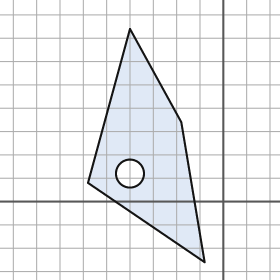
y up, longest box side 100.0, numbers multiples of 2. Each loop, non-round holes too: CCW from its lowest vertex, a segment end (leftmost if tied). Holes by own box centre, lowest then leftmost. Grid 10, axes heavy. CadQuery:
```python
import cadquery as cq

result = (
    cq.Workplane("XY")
    .moveTo(-8.0, -26.0)
    .lineTo(-18.0, 34.0)
    .lineTo(-40.0, 74.0)
    .lineTo(-58.0, 8.0)
    .close()
    .moveTo(-40.0, 12.0)
    .circle(6.0)
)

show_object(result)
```